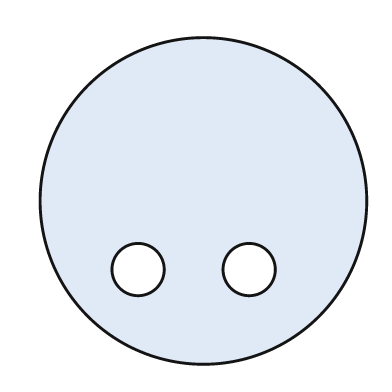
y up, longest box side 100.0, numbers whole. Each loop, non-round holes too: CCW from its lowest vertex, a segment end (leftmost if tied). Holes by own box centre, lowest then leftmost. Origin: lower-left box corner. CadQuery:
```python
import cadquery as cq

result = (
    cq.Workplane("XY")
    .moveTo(50.0, 50.0)
    .circle(50.0)
    .moveTo(30.0, 29.0)
    .circle(8.0)
    .moveTo(64.0, 29.0)
    .circle(8.0)
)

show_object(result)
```